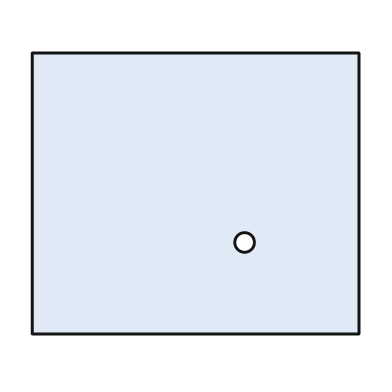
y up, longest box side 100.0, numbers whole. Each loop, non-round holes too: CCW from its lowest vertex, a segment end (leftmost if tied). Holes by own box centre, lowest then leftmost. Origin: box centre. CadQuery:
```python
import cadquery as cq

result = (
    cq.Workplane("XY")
    .moveTo(-50.0, -43.0)
    .lineTo(50.0, -43.0)
    .lineTo(50.0, 43.0)
    .lineTo(-50.0, 43.0)
    .close()
    .moveTo(15.0, -15.0)
    .circle(3.0)
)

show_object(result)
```